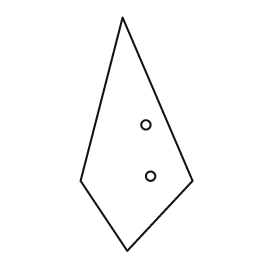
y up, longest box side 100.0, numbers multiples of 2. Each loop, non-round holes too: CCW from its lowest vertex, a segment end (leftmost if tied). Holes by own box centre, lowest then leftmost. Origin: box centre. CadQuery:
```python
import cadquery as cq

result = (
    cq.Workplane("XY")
    .moveTo(-4.0, -50.0)
    .lineTo(24.0, -20.0)
    .lineTo(-6.0, 50.0)
    .lineTo(-24.0, -20.0)
    .close()
    .moveTo(6.0, -18.0)
    .circle(2.0)
    .moveTo(4.0, 4.0)
    .circle(2.0)
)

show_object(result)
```